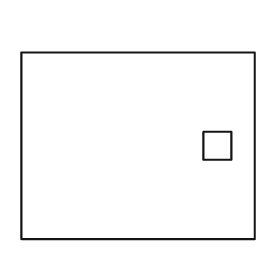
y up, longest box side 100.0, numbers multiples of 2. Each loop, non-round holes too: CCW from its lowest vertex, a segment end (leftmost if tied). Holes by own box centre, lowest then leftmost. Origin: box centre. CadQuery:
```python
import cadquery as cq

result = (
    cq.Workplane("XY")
    .moveTo(-50.0, -40.0)
    .lineTo(50.0, -40.0)
    .lineTo(50.0, 40.0)
    .lineTo(-50.0, 40.0)
    .close()
    .moveTo(28.0, -6.0)
    .lineTo(40.0, -6.0)
    .lineTo(40.0, 6.0)
    .lineTo(28.0, 6.0)
    .close()
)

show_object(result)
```